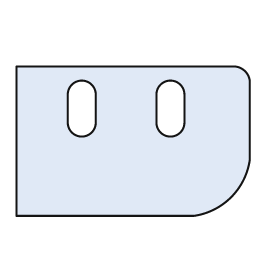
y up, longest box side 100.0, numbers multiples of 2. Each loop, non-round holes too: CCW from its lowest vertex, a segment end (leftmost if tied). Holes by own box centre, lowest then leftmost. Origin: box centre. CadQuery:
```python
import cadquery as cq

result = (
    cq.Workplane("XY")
    .moveTo(-50.0, -32.0)
    .lineTo(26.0, -32.0)
    .threePointArc((42.0, -24.0), (50.0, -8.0))
    .lineTo(50.0, 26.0)
    .threePointArc((48.0, 30.0), (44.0, 32.0))
    .lineTo(-50.0, 32.0)
    .close()
    .moveTo(-28.0, 8.0)
    .threePointArc((-22.0, 2.0), (-16.0, 8.0))
    .lineTo(-16.0, 20.0)
    .threePointArc((-22.0, 26.0), (-28.0, 20.0))
    .close()
    .moveTo(10.0, 8.0)
    .threePointArc((16.0, 2.0), (22.0, 8.0))
    .lineTo(22.0, 20.0)
    .threePointArc((16.0, 26.0), (10.0, 20.0))
    .close()
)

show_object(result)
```